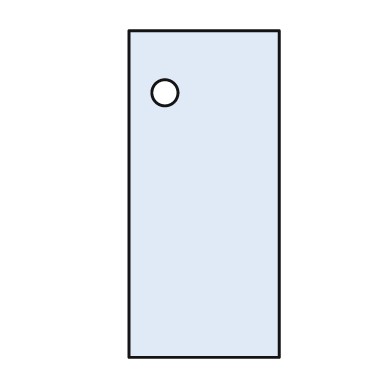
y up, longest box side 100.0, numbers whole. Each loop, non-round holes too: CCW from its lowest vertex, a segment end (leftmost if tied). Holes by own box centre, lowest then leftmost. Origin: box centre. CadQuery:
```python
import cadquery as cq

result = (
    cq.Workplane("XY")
    .moveTo(-23.0, -50.0)
    .lineTo(23.0, -50.0)
    .lineTo(23.0, 50.0)
    .lineTo(-23.0, 50.0)
    .close()
    .moveTo(-12.0, 31.0)
    .circle(4.0)
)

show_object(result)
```